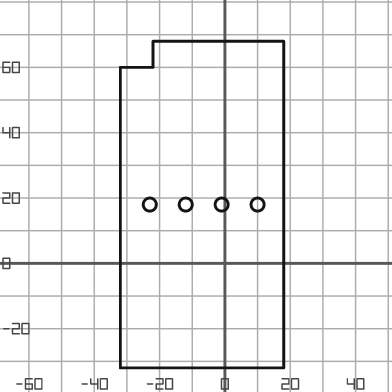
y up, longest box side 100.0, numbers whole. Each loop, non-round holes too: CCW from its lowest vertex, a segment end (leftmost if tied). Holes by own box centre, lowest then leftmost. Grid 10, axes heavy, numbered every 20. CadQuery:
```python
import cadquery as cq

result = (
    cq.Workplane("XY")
    .moveTo(-32.0, -32.0)
    .lineTo(18.0, -32.0)
    .lineTo(18.0, 68.0)
    .lineTo(-22.0, 68.0)
    .lineTo(-22.0, 60.0)
    .lineTo(-32.0, 60.0)
    .close()
    .moveTo(-23.0, 18.0)
    .circle(2.0)
    .moveTo(-12.0, 18.0)
    .circle(2.0)
    .moveTo(-1.0, 18.0)
    .circle(2.0)
    .moveTo(10.0, 18.0)
    .circle(2.0)
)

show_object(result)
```